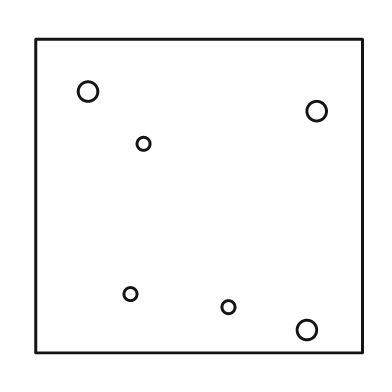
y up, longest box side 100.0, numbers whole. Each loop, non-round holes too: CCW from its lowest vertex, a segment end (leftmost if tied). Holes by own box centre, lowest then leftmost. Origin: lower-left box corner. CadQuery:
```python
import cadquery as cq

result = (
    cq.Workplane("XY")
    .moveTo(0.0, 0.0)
    .lineTo(100.0, 0.0)
    .lineTo(100.0, 96.0)
    .lineTo(0.0, 96.0)
    .close()
    .moveTo(83.0, 7.0)
    .circle(3.0)
    .moveTo(59.0, 14.0)
    .circle(2.0)
    .moveTo(29.0, 18.0)
    .circle(2.0)
    .moveTo(33.0, 64.0)
    .circle(2.0)
    .moveTo(86.0, 74.0)
    .circle(3.0)
    .moveTo(16.0, 80.0)
    .circle(3.0)
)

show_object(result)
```